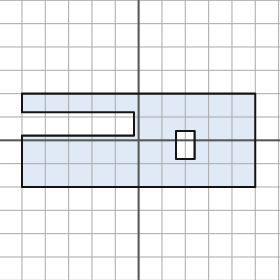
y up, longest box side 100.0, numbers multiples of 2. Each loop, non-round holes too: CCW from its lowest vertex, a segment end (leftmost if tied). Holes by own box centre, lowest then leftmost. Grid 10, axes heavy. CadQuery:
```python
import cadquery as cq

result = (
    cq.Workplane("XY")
    .moveTo(-50.0, -20.0)
    .lineTo(50.0, -20.0)
    .lineTo(50.0, 20.0)
    .lineTo(-50.0, 20.0)
    .lineTo(-50.0, 12.0)
    .lineTo(-2.0, 12.0)
    .lineTo(-2.0, 2.0)
    .lineTo(-50.0, 2.0)
    .close()
    .moveTo(16.0, -8.0)
    .lineTo(24.0, -8.0)
    .lineTo(24.0, 4.0)
    .lineTo(16.0, 4.0)
    .close()
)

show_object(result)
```